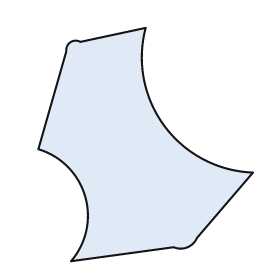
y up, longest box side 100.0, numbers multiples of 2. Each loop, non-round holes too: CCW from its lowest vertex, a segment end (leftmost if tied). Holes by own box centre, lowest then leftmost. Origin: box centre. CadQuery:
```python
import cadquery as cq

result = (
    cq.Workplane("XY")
    .moveTo(-32.0, -50.0)
    .lineTo(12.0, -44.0)
    .threePointArc((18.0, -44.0), (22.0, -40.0))
    .lineTo(46.0, -12.0)
    .threePointArc((8.0, 8.0), (0.0, 50.0))
    .lineTo(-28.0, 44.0)
    .threePointArc((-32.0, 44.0), (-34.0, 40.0))
    .lineTo(-46.0, -2.0)
    .threePointArc((-26.0, -22.0), (-32.0, -50.0))
    .close()
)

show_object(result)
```